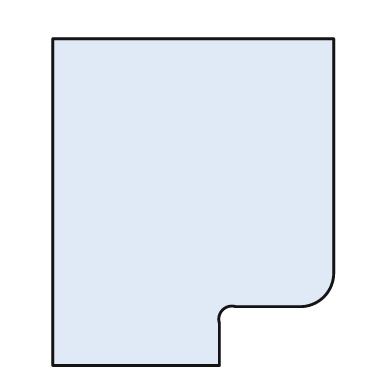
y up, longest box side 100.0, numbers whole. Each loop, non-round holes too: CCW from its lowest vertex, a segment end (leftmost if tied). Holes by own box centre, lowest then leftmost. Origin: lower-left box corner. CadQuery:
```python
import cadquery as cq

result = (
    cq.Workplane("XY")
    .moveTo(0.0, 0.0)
    .lineTo(51.0, 0.0)
    .lineTo(51.0, 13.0)
    .threePointArc((52.0, 17.0), (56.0, 18.0))
    .lineTo(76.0, 18.0)
    .threePointArc((83.0, 21.0), (86.0, 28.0))
    .lineTo(86.0, 100.0)
    .lineTo(0.0, 100.0)
    .close()
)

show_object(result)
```